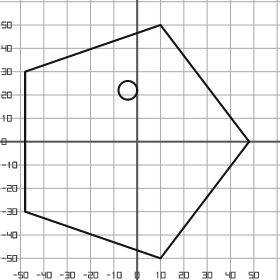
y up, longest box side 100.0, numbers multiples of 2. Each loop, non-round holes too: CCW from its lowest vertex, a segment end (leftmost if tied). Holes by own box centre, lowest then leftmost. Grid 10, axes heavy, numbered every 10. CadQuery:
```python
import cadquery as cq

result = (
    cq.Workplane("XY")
    .moveTo(10.0, -50.0)
    .lineTo(48.0, 0.0)
    .lineTo(10.0, 50.0)
    .lineTo(-48.0, 30.0)
    .lineTo(-48.0, -30.0)
    .close()
    .moveTo(-4.0, 22.0)
    .circle(4.0)
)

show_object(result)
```